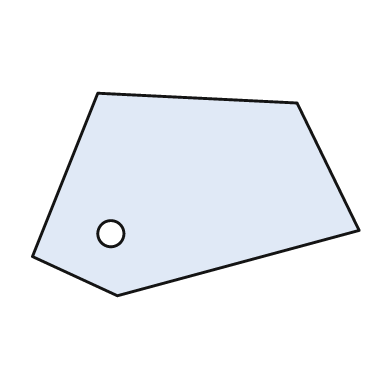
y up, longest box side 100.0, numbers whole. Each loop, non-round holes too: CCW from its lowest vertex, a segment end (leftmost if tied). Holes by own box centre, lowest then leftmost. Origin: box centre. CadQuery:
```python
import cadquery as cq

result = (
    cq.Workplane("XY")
    .moveTo(-24.0, -31.0)
    .lineTo(50.0, -11.0)
    .lineTo(31.0, 28.0)
    .lineTo(-30.0, 31.0)
    .lineTo(-50.0, -19.0)
    .close()
    .moveTo(-26.0, -12.0)
    .circle(4.0)
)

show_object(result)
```